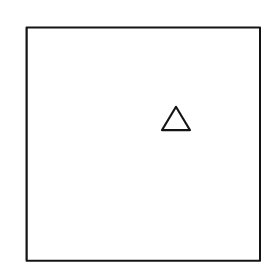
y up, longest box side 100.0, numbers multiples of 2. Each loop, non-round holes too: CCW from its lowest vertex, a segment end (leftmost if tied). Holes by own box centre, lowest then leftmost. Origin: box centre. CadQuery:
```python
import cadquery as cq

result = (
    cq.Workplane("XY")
    .moveTo(-50.0, -50.0)
    .lineTo(50.0, -50.0)
    .lineTo(50.0, 50.0)
    .lineTo(-50.0, 50.0)
    .close()
    .moveTo(8.0, 6.0)
    .lineTo(20.0, 6.0)
    .lineTo(14.0, 16.0)
    .close()
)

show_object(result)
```